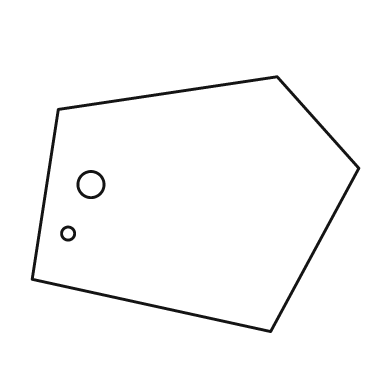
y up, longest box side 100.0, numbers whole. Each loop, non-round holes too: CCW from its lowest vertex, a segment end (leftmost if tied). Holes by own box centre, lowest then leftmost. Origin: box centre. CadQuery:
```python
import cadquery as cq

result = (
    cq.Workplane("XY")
    .moveTo(23.0, -39.0)
    .lineTo(50.0, 11.0)
    .lineTo(25.0, 39.0)
    .lineTo(-42.0, 29.0)
    .lineTo(-50.0, -23.0)
    .close()
    .moveTo(-39.0, -9.0)
    .circle(2.0)
    .moveTo(-32.0, 6.0)
    .circle(4.0)
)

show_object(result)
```